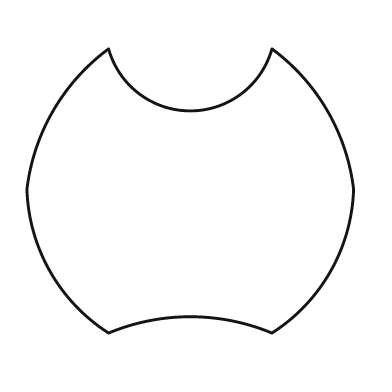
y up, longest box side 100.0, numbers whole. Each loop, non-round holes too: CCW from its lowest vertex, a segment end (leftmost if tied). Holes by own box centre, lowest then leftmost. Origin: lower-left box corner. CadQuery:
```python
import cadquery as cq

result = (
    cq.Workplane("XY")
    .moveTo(25.0, 0.0)
    .threePointArc((50.0, 5.0), (75.0, 0.0))
    .threePointArc((93.0, 19.0), (100.0, 44.0))
    .threePointArc((92.0, 68.0), (75.0, 87.0))
    .threePointArc((50.0, 68.0), (25.0, 87.0))
    .threePointArc((8.0, 68.0), (0.0, 44.0))
    .threePointArc((7.0, 19.0), (25.0, 0.0))
    .close()
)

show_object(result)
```